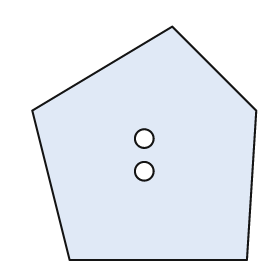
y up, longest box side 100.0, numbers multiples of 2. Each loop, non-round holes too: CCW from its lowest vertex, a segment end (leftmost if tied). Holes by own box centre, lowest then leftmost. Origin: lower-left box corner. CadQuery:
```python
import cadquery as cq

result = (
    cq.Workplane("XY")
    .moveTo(16.0, 0.0)
    .lineTo(92.0, 0.0)
    .lineTo(96.0, 64.0)
    .lineTo(60.0, 100.0)
    .lineTo(0.0, 64.0)
    .close()
    .moveTo(48.0, 38.0)
    .circle(4.0)
    .moveTo(48.0, 52.0)
    .circle(4.0)
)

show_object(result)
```